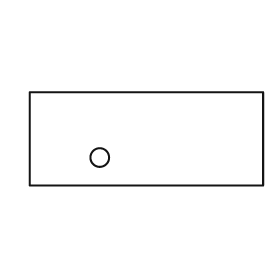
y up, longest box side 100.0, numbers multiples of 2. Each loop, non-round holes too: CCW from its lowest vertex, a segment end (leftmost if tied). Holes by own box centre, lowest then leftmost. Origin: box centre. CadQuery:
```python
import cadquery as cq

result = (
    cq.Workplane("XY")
    .moveTo(-50.0, -20.0)
    .lineTo(50.0, -20.0)
    .lineTo(50.0, 20.0)
    .lineTo(-50.0, 20.0)
    .close()
    .moveTo(-20.0, -8.0)
    .circle(4.0)
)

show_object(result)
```